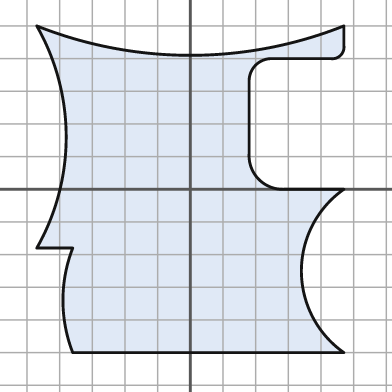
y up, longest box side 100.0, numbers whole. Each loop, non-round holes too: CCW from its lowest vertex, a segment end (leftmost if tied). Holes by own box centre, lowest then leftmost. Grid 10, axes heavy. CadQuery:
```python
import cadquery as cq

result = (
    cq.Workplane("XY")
    .moveTo(-36.0, -50.0)
    .lineTo(47.0, -50.0)
    .threePointArc((34.0, -25.0), (47.0, 0.0))
    .lineTo(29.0, 0.0)
    .threePointArc((21.0, 3.0), (18.0, 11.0))
    .lineTo(18.0, 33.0)
    .threePointArc((20.0, 38.0), (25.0, 40.0))
    .lineTo(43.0, 40.0)
    .threePointArc((46.0, 41.0), (47.0, 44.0))
    .lineTo(47.0, 50.0)
    .threePointArc((0.0, 41.0), (-47.0, 50.0))
    .threePointArc((-38.0, 16.0), (-47.0, -18.0))
    .lineTo(-36.0, -18.0)
    .threePointArc((-39.0, -34.0), (-36.0, -50.0))
    .close()
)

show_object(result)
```